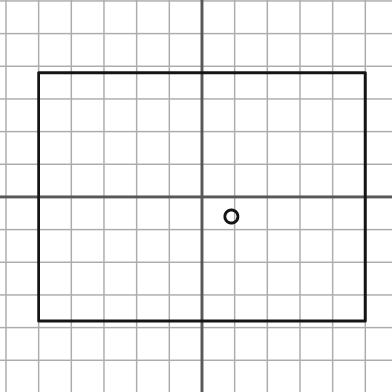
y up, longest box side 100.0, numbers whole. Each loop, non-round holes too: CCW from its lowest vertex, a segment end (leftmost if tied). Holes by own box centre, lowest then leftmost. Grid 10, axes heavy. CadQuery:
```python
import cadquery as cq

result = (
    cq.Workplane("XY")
    .moveTo(-50.0, -38.0)
    .lineTo(50.0, -38.0)
    .lineTo(50.0, 38.0)
    .lineTo(-50.0, 38.0)
    .close()
    .moveTo(9.0, -6.0)
    .circle(2.0)
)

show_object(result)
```